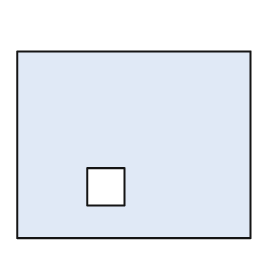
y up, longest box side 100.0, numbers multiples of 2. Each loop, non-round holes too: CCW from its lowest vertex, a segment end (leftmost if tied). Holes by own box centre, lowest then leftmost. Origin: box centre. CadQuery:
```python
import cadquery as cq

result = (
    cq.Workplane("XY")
    .moveTo(-50.0, -40.0)
    .lineTo(50.0, -40.0)
    .lineTo(50.0, 40.0)
    .lineTo(-50.0, 40.0)
    .close()
    .moveTo(-20.0, -26.0)
    .lineTo(-4.0, -26.0)
    .lineTo(-4.0, -10.0)
    .lineTo(-20.0, -10.0)
    .close()
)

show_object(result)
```